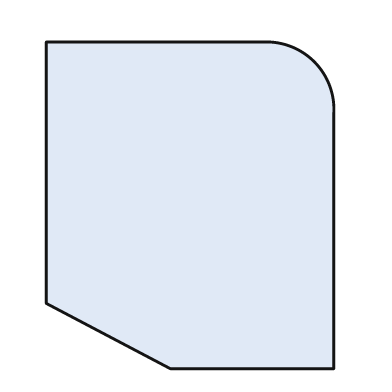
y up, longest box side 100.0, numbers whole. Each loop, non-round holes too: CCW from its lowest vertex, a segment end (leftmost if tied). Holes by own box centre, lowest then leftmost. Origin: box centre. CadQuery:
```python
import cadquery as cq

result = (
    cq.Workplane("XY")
    .moveTo(-6.0, -50.0)
    .lineTo(44.0, -50.0)
    .lineTo(44.0, 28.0)
    .threePointArc((38.0, 44.0), (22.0, 50.0))
    .lineTo(-44.0, 50.0)
    .lineTo(-44.0, -30.0)
    .close()
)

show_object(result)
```